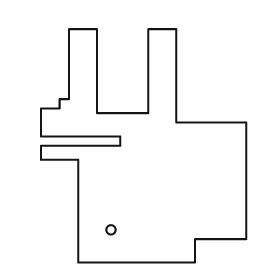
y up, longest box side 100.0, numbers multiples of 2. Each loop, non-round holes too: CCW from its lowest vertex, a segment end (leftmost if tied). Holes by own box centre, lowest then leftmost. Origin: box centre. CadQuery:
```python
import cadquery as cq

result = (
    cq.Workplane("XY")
    .moveTo(-28.0, -50.0)
    .lineTo(22.0, -50.0)
    .lineTo(22.0, -40.0)
    .lineTo(44.0, -40.0)
    .lineTo(44.0, 10.0)
    .lineTo(14.0, 10.0)
    .lineTo(14.0, 50.0)
    .lineTo(2.0, 50.0)
    .lineTo(2.0, 14.0)
    .lineTo(-20.0, 14.0)
    .lineTo(-20.0, 50.0)
    .lineTo(-32.0, 50.0)
    .lineTo(-32.0, 20.0)
    .lineTo(-36.0, 20.0)
    .lineTo(-36.0, 16.0)
    .lineTo(-44.0, 16.0)
    .lineTo(-44.0, 4.0)
    .lineTo(-10.0, 4.0)
    .lineTo(-10.0, 0.0)
    .lineTo(-44.0, 0.0)
    .lineTo(-44.0, -6.0)
    .lineTo(-28.0, -6.0)
    .close()
    .moveTo(-14.0, -36.0)
    .circle(2.0)
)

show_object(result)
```